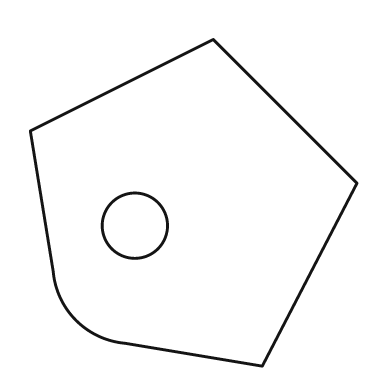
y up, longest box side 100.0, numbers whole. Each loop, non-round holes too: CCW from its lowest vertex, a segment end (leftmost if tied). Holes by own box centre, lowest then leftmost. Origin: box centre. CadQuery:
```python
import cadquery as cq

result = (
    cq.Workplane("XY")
    .moveTo(21.0, -50.0)
    .lineTo(50.0, 6.0)
    .lineTo(6.0, 50.0)
    .lineTo(-50.0, 22.0)
    .lineTo(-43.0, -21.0)
    .threePointArc((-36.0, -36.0), (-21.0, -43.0))
    .close()
    .moveTo(-18.0, -7.0)
    .circle(10.0)
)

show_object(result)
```